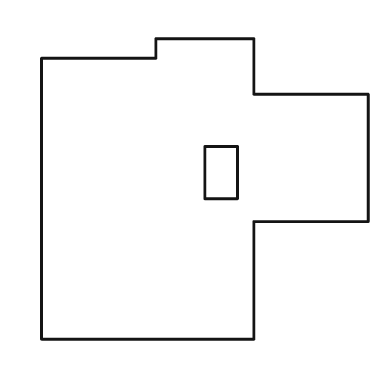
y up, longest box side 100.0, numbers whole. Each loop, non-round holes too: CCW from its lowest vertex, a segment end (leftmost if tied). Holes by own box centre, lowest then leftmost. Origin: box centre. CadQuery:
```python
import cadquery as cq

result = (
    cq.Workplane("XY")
    .moveTo(-50.0, -46.0)
    .lineTo(15.0, -46.0)
    .lineTo(15.0, -10.0)
    .lineTo(50.0, -10.0)
    .lineTo(50.0, 29.0)
    .lineTo(15.0, 29.0)
    .lineTo(15.0, 46.0)
    .lineTo(-15.0, 46.0)
    .lineTo(-15.0, 40.0)
    .lineTo(-50.0, 40.0)
    .close()
    .moveTo(0.0, -3.0)
    .lineTo(10.0, -3.0)
    .lineTo(10.0, 13.0)
    .lineTo(0.0, 13.0)
    .close()
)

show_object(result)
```